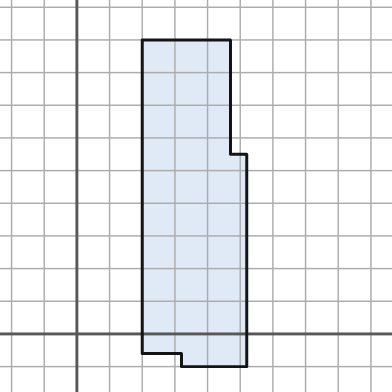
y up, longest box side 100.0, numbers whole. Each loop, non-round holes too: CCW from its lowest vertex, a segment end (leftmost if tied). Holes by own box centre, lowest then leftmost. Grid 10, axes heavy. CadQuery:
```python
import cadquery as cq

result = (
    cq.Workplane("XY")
    .moveTo(32.0, -10.0)
    .lineTo(52.0, -10.0)
    .lineTo(52.0, 55.0)
    .lineTo(47.0, 55.0)
    .lineTo(47.0, 90.0)
    .lineTo(20.0, 90.0)
    .lineTo(20.0, -6.0)
    .lineTo(32.0, -6.0)
    .close()
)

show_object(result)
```